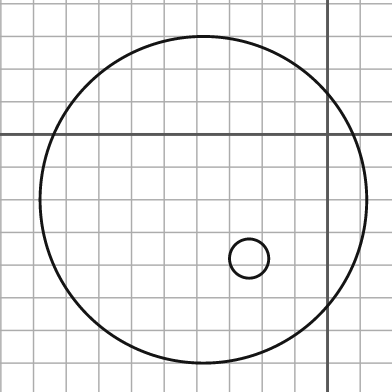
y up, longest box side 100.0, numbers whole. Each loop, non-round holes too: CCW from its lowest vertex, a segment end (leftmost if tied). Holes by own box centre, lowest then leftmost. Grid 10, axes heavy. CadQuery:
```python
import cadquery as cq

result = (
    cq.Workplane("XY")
    .moveTo(-38.0, -20.0)
    .circle(50.0)
    .moveTo(-24.0, -38.0)
    .circle(6.0)
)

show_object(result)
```